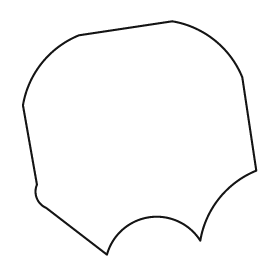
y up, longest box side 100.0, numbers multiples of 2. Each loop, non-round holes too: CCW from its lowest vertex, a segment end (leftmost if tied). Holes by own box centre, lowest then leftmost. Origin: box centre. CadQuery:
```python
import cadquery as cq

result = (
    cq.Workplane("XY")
    .moveTo(-14.0, -50.0)
    .threePointArc((4.0, -34.0), (26.0, -44.0))
    .threePointArc((34.0, -26.0), (50.0, -14.0))
    .lineTo(44.0, 26.0)
    .threePointArc((32.0, 42.0), (14.0, 50.0))
    .lineTo(-26.0, 44.0)
    .threePointArc((-42.0, 32.0), (-50.0, 14.0))
    .lineTo(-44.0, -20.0)
    .threePointArc((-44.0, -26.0), (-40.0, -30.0))
    .close()
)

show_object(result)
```